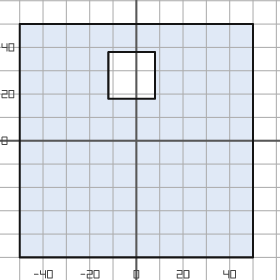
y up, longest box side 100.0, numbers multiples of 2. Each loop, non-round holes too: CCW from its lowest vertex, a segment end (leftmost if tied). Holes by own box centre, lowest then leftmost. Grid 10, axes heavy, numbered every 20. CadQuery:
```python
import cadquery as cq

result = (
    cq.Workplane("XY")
    .moveTo(-50.0, -50.0)
    .lineTo(50.0, -50.0)
    .lineTo(50.0, 50.0)
    .lineTo(-50.0, 50.0)
    .close()
    .moveTo(-12.0, 18.0)
    .lineTo(8.0, 18.0)
    .lineTo(8.0, 38.0)
    .lineTo(-12.0, 38.0)
    .close()
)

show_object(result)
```